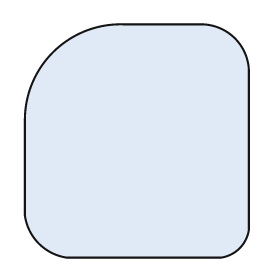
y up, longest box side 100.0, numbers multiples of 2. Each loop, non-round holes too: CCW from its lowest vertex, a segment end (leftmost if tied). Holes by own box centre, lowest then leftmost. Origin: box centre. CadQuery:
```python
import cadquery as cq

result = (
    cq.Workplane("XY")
    .moveTo(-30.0, -50.0)
    .lineTo(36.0, -50.0)
    .threePointArc((44.0, -46.0), (48.0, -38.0))
    .lineTo(48.0, 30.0)
    .threePointArc((42.0, 44.0), (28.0, 50.0))
    .lineTo(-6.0, 50.0)
    .threePointArc((-36.0, 38.0), (-48.0, 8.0))
    .lineTo(-48.0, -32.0)
    .threePointArc((-42.0, -44.0), (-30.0, -50.0))
    .close()
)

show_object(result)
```